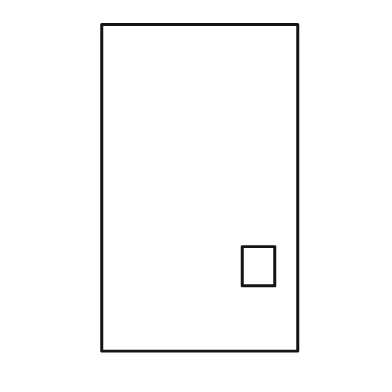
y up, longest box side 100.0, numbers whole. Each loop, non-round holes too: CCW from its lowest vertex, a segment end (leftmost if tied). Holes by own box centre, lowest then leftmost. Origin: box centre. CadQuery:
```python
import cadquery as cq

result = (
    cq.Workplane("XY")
    .moveTo(-30.0, -50.0)
    .lineTo(30.0, -50.0)
    .lineTo(30.0, 50.0)
    .lineTo(-30.0, 50.0)
    .close()
    .moveTo(13.0, -30.0)
    .lineTo(23.0, -30.0)
    .lineTo(23.0, -18.0)
    .lineTo(13.0, -18.0)
    .close()
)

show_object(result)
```